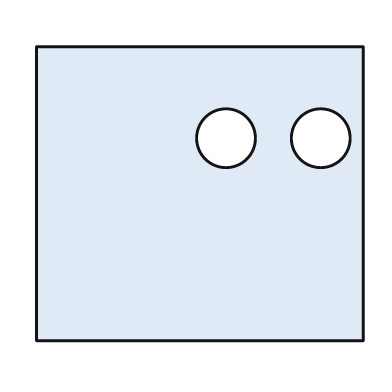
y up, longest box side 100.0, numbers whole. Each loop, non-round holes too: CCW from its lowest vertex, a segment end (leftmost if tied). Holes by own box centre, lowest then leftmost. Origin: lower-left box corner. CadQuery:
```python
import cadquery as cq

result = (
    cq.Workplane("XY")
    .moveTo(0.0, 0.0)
    .lineTo(100.0, 0.0)
    .lineTo(100.0, 90.0)
    .lineTo(0.0, 90.0)
    .close()
    .moveTo(58.0, 62.0)
    .circle(9.0)
    .moveTo(87.0, 62.0)
    .circle(9.0)
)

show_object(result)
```